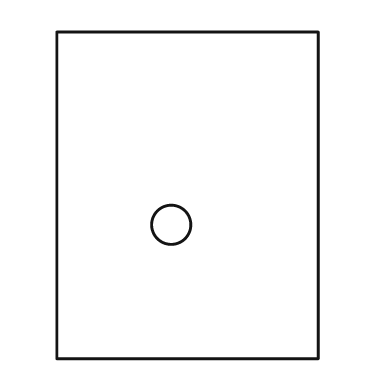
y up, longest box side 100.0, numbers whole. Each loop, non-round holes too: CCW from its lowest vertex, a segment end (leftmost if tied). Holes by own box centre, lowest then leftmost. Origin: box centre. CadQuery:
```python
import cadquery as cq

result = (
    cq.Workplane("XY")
    .moveTo(-40.0, -50.0)
    .lineTo(40.0, -50.0)
    .lineTo(40.0, 50.0)
    .lineTo(-40.0, 50.0)
    .close()
    .moveTo(-5.0, -9.0)
    .circle(6.0)
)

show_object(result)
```